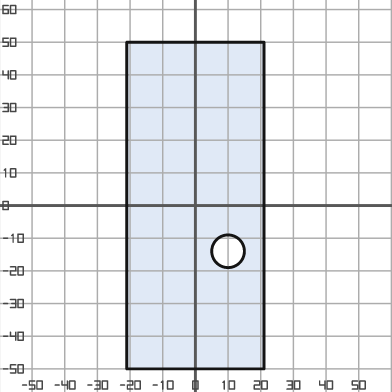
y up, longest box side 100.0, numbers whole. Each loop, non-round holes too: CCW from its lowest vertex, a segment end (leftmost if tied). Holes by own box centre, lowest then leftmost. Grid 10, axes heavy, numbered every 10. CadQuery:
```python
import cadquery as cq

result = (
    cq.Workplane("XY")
    .moveTo(-21.0, -50.0)
    .lineTo(21.0, -50.0)
    .lineTo(21.0, 50.0)
    .lineTo(-21.0, 50.0)
    .close()
    .moveTo(10.0, -14.0)
    .circle(5.0)
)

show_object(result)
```